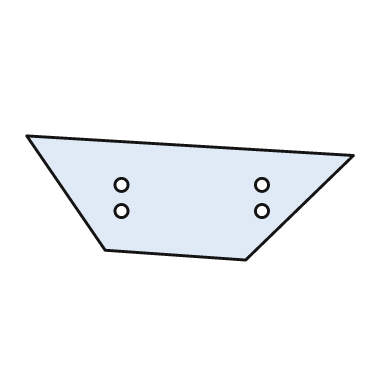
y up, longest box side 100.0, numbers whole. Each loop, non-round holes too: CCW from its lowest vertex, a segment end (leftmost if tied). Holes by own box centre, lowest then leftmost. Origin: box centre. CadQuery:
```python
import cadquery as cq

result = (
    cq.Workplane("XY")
    .moveTo(17.0, -19.0)
    .lineTo(50.0, 13.0)
    .lineTo(-50.0, 19.0)
    .lineTo(-26.0, -16.0)
    .close()
    .moveTo(-21.0, -4.0)
    .circle(2.0)
    .moveTo(22.0, -4.0)
    .circle(2.0)
    .moveTo(-21.0, 4.0)
    .circle(2.0)
    .moveTo(22.0, 4.0)
    .circle(2.0)
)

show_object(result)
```